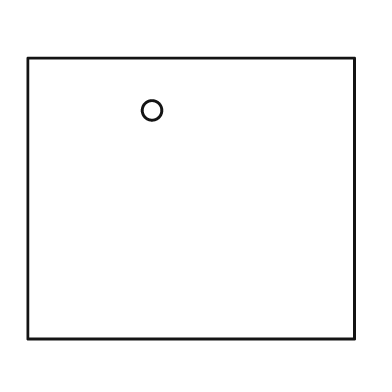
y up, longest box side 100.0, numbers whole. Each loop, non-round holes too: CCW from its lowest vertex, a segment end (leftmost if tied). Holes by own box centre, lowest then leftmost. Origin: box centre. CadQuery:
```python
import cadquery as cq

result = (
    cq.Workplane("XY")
    .moveTo(-50.0, -43.0)
    .lineTo(50.0, -43.0)
    .lineTo(50.0, 43.0)
    .lineTo(-50.0, 43.0)
    .close()
    .moveTo(-12.0, 27.0)
    .circle(3.0)
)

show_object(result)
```